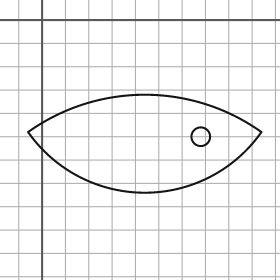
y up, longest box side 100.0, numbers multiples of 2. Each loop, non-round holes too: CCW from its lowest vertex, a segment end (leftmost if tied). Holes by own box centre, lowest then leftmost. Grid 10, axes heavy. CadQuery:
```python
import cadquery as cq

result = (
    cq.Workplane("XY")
    .moveTo(-6.0, -48.0)
    .threePointArc((44.0, -74.0), (94.0, -48.0))
    .threePointArc((44.0, -32.0), (-6.0, -48.0))
    .close()
    .moveTo(68.0, -50.0)
    .circle(4.0)
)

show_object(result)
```